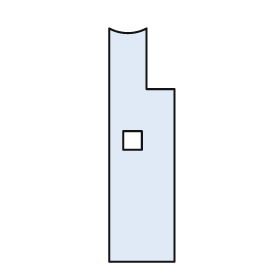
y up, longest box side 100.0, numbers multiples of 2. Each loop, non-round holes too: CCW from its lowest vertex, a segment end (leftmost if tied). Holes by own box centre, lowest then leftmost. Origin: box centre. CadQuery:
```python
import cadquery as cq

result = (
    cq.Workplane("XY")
    .moveTo(-14.0, -50.0)
    .lineTo(14.0, -50.0)
    .lineTo(14.0, 24.0)
    .lineTo(2.0, 24.0)
    .lineTo(2.0, 50.0)
    .threePointArc((-6.0, 48.0), (-14.0, 50.0))
    .close()
    .moveTo(-8.0, -2.0)
    .lineTo(0.0, -2.0)
    .lineTo(0.0, 6.0)
    .lineTo(-8.0, 6.0)
    .close()
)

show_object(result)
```